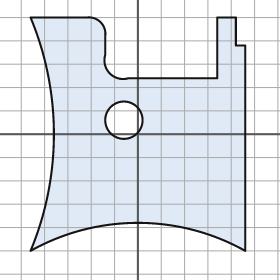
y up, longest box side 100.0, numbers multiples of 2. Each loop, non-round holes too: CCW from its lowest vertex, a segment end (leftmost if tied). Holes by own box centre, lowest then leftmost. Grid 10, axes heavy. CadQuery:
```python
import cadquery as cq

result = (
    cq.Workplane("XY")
    .moveTo(-46.0, -50.0)
    .threePointArc((0.0, -38.0), (46.0, -50.0))
    .lineTo(46.0, 38.0)
    .lineTo(42.0, 38.0)
    .lineTo(42.0, 50.0)
    .lineTo(34.0, 50.0)
    .lineTo(34.0, 24.0)
    .lineTo(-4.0, 24.0)
    .threePointArc((-12.0, 26.0), (-14.0, 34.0))
    .lineTo(-14.0, 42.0)
    .threePointArc((-16.0, 48.0), (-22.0, 50.0))
    .lineTo(-46.0, 50.0)
    .threePointArc((-36.0, 0.0), (-46.0, -50.0))
    .close()
    .moveTo(-6.0, 6.0)
    .circle(8.0)
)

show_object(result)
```